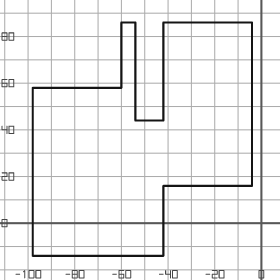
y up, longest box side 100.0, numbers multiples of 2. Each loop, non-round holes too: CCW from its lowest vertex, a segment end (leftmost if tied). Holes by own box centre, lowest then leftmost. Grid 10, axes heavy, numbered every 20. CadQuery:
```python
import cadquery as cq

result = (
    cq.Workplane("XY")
    .moveTo(-98.0, -14.0)
    .lineTo(-42.0, -14.0)
    .lineTo(-42.0, 16.0)
    .lineTo(-4.0, 16.0)
    .lineTo(-4.0, 86.0)
    .lineTo(-42.0, 86.0)
    .lineTo(-42.0, 44.0)
    .lineTo(-54.0, 44.0)
    .lineTo(-54.0, 86.0)
    .lineTo(-60.0, 86.0)
    .lineTo(-60.0, 58.0)
    .lineTo(-98.0, 58.0)
    .close()
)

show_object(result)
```